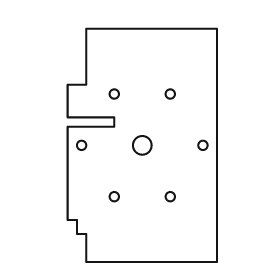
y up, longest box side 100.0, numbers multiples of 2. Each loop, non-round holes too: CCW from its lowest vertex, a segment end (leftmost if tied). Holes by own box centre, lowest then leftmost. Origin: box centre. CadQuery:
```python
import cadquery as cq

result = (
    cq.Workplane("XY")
    .moveTo(-24.0, -50.0)
    .lineTo(32.0, -50.0)
    .lineTo(32.0, 50.0)
    .lineTo(-24.0, 50.0)
    .lineTo(-24.0, 26.0)
    .lineTo(-32.0, 26.0)
    .lineTo(-32.0, 12.0)
    .lineTo(-12.0, 12.0)
    .lineTo(-12.0, 8.0)
    .lineTo(-32.0, 8.0)
    .lineTo(-32.0, -32.0)
    .lineTo(-28.0, -32.0)
    .lineTo(-28.0, -38.0)
    .lineTo(-24.0, -38.0)
    .close()
    .moveTo(-12.0, -22.0)
    .circle(2.0)
    .moveTo(12.0, -22.0)
    .circle(2.0)
    .moveTo(-26.0, 0.0)
    .circle(2.0)
    .moveTo(0.0, 0.0)
    .circle(4.0)
    .moveTo(26.0, 0.0)
    .circle(2.0)
    .moveTo(-12.0, 22.0)
    .circle(2.0)
    .moveTo(12.0, 22.0)
    .circle(2.0)
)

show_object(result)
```